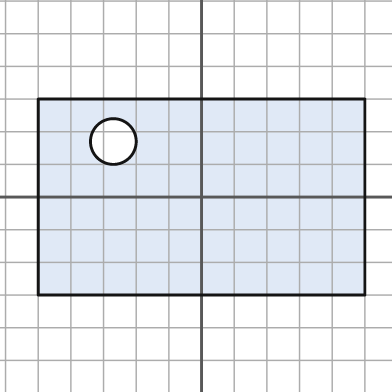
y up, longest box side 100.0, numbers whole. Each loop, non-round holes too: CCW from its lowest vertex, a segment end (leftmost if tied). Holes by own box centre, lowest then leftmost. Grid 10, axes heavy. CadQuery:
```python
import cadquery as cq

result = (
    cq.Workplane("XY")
    .moveTo(-50.0, -30.0)
    .lineTo(50.0, -30.0)
    .lineTo(50.0, 30.0)
    .lineTo(-50.0, 30.0)
    .close()
    .moveTo(-27.0, 17.0)
    .circle(7.0)
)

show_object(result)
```